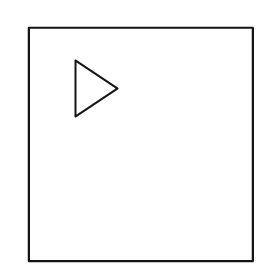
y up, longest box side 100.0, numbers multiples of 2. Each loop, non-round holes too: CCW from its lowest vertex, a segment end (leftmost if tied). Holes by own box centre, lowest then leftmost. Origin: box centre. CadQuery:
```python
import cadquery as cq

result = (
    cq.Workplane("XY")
    .moveTo(-48.0, -50.0)
    .lineTo(48.0, -50.0)
    .lineTo(48.0, 50.0)
    .lineTo(-48.0, 50.0)
    .close()
    .moveTo(-28.0, 12.0)
    .lineTo(-10.0, 24.0)
    .lineTo(-28.0, 36.0)
    .close()
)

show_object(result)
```